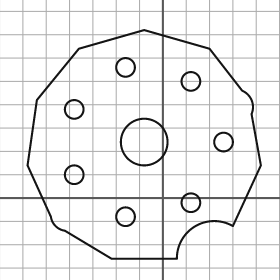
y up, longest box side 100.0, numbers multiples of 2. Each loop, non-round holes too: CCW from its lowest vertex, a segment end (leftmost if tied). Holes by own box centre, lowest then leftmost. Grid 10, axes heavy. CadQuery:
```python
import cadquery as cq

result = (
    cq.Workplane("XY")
    .moveTo(-22.0, -26.0)
    .lineTo(6.0, -26.0)
    .threePointArc((14.0, -12.0), (30.0, -12.0))
    .lineTo(42.0, 14.0)
    .lineTo(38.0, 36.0)
    .threePointArc((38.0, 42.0), (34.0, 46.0))
    .lineTo(20.0, 64.0)
    .lineTo(-8.0, 72.0)
    .lineTo(-36.0, 64.0)
    .lineTo(-54.0, 42.0)
    .lineTo(-58.0, 14.0)
    .lineTo(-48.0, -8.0)
    .threePointArc((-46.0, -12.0), (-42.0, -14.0))
    .close()
    .moveTo(-16.0, -8.0)
    .circle(4.0)
    .moveTo(12.0, -2.0)
    .circle(4.0)
    .moveTo(-38.0, 10.0)
    .circle(4.0)
    .moveTo(-8.0, 24.0)
    .circle(10.0)
    .moveTo(26.0, 24.0)
    .circle(4.0)
    .moveTo(-38.0, 38.0)
    .circle(4.0)
    .moveTo(12.0, 50.0)
    .circle(4.0)
    .moveTo(-16.0, 56.0)
    .circle(4.0)
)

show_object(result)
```